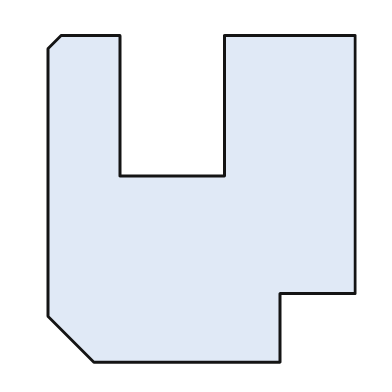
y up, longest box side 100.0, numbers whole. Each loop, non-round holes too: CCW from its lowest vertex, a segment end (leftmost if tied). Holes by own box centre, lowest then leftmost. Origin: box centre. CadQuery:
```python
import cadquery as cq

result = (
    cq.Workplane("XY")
    .moveTo(-33.0, -50.0)
    .lineTo(24.0, -50.0)
    .lineTo(24.0, -29.0)
    .lineTo(47.0, -29.0)
    .lineTo(47.0, 50.0)
    .lineTo(7.0, 50.0)
    .lineTo(7.0, 7.0)
    .lineTo(-25.0, 7.0)
    .lineTo(-25.0, 50.0)
    .lineTo(-43.0, 50.0)
    .lineTo(-47.0, 46.0)
    .lineTo(-47.0, -36.0)
    .close()
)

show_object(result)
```